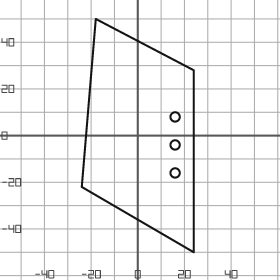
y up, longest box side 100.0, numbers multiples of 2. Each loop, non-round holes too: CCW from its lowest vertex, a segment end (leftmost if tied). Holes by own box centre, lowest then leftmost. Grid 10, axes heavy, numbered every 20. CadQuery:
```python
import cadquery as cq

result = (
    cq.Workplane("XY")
    .moveTo(24.0, -50.0)
    .lineTo(24.0, 28.0)
    .lineTo(-18.0, 50.0)
    .lineTo(-24.0, -22.0)
    .close()
    .moveTo(16.0, -16.0)
    .circle(2.0)
    .moveTo(16.0, -4.0)
    .circle(2.0)
    .moveTo(16.0, 8.0)
    .circle(2.0)
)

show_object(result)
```